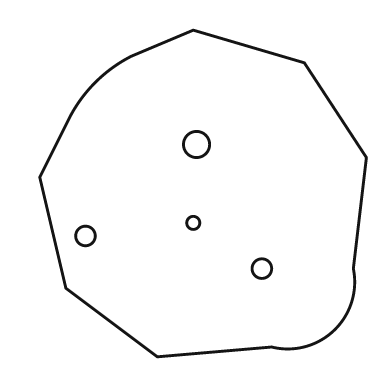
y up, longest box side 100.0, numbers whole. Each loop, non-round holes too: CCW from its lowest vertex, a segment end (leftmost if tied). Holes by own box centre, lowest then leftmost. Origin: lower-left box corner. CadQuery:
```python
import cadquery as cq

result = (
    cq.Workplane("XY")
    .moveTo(36.0, 0.0)
    .lineTo(71.0, 3.0)
    .threePointArc((90.0, 8.0), (96.0, 27.0))
    .lineTo(100.0, 61.0)
    .lineTo(81.0, 90.0)
    .lineTo(47.0, 100.0)
    .lineTo(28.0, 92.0)
    .threePointArc((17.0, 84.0), (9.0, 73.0))
    .lineTo(0.0, 55.0)
    .lineTo(8.0, 21.0)
    .close()
    .moveTo(68.0, 27.0)
    .circle(3.0)
    .moveTo(14.0, 37.0)
    .circle(3.0)
    .moveTo(47.0, 41.0)
    .circle(2.0)
    .moveTo(48.0, 65.0)
    .circle(4.0)
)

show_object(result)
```